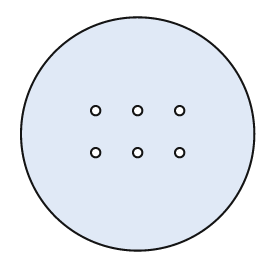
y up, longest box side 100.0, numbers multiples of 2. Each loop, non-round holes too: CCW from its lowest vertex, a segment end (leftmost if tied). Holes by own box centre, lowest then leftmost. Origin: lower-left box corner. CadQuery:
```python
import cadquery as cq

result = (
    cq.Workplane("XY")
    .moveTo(50.0, 50.0)
    .circle(50.0)
    .moveTo(32.0, 42.0)
    .circle(2.0)
    .moveTo(50.0, 42.0)
    .circle(2.0)
    .moveTo(68.0, 42.0)
    .circle(2.0)
    .moveTo(32.0, 60.0)
    .circle(2.0)
    .moveTo(50.0, 60.0)
    .circle(2.0)
    .moveTo(68.0, 60.0)
    .circle(2.0)
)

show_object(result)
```